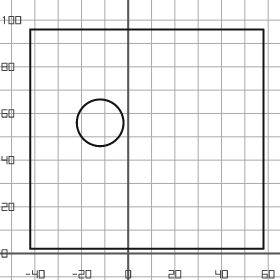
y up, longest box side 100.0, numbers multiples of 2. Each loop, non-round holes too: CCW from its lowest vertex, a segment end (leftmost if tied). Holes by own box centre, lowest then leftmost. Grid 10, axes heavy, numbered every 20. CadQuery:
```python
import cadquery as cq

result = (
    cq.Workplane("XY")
    .moveTo(-42.0, 2.0)
    .lineTo(58.0, 2.0)
    .lineTo(58.0, 96.0)
    .lineTo(-42.0, 96.0)
    .close()
    .moveTo(-12.0, 56.0)
    .circle(10.0)
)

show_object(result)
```